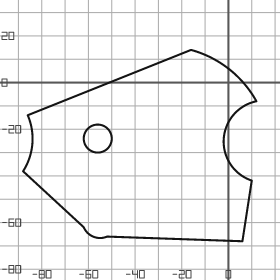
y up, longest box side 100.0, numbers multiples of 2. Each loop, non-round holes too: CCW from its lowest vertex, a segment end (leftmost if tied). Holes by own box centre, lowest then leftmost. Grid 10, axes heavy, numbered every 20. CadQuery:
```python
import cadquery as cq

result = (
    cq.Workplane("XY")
    .moveTo(6.0, -68.0)
    .lineTo(10.0, -42.0)
    .threePointArc((-2.0, -24.0), (12.0, -8.0))
    .threePointArc((0.0, 6.0), (-16.0, 14.0))
    .lineTo(-86.0, -14.0)
    .threePointArc((-84.0, -26.0), (-88.0, -38.0))
    .lineTo(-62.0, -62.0)
    .threePointArc((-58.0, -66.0), (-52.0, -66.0))
    .close()
    .moveTo(-56.0, -24.0)
    .circle(6.0)
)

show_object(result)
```